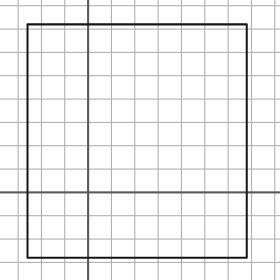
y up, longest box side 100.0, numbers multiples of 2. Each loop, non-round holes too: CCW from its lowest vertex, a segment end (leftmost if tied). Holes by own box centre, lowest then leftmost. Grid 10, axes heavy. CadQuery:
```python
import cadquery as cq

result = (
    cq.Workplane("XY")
    .moveTo(-26.0, -28.0)
    .lineTo(68.0, -28.0)
    .lineTo(68.0, 72.0)
    .lineTo(-26.0, 72.0)
    .close()
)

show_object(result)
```